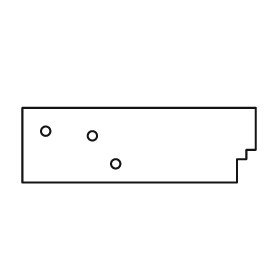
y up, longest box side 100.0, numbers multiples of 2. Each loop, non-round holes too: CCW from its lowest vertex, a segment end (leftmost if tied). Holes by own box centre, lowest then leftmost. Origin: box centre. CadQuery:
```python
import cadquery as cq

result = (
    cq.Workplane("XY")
    .moveTo(-50.0, -16.0)
    .lineTo(42.0, -16.0)
    .lineTo(42.0, -6.0)
    .lineTo(46.0, -6.0)
    .lineTo(46.0, -2.0)
    .lineTo(50.0, -2.0)
    .lineTo(50.0, 16.0)
    .lineTo(-50.0, 16.0)
    .close()
    .moveTo(-10.0, -8.0)
    .circle(2.0)
    .moveTo(-20.0, 4.0)
    .circle(2.0)
    .moveTo(-40.0, 6.0)
    .circle(2.0)
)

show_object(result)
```